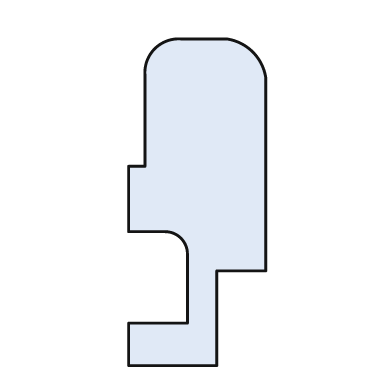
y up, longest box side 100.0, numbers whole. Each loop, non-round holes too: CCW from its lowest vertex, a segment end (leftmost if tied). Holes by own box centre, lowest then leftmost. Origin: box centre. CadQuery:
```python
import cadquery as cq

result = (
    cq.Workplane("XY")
    .moveTo(-21.0, -50.0)
    .lineTo(6.0, -50.0)
    .lineTo(6.0, -21.0)
    .lineTo(21.0, -21.0)
    .lineTo(21.0, 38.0)
    .threePointArc((17.0, 46.0), (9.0, 50.0))
    .lineTo(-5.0, 50.0)
    .threePointArc((-13.0, 47.0), (-16.0, 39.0))
    .lineTo(-16.0, 11.0)
    .lineTo(-21.0, 11.0)
    .lineTo(-21.0, -9.0)
    .lineTo(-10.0, -9.0)
    .threePointArc((-5.0, -11.0), (-3.0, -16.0))
    .lineTo(-3.0, -37.0)
    .lineTo(-21.0, -37.0)
    .close()
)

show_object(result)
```